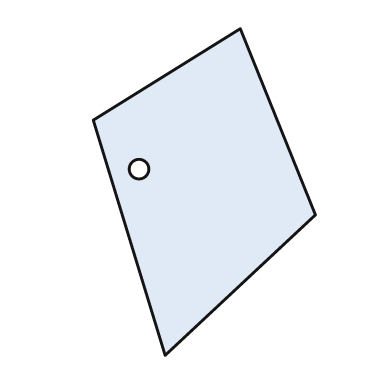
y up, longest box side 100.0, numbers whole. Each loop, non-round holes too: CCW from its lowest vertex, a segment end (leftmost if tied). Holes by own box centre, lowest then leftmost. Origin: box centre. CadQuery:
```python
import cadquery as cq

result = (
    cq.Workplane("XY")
    .moveTo(-12.0, -50.0)
    .lineTo(34.0, -7.0)
    .lineTo(11.0, 50.0)
    .lineTo(-34.0, 22.0)
    .close()
    .moveTo(-20.0, 7.0)
    .circle(3.0)
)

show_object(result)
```